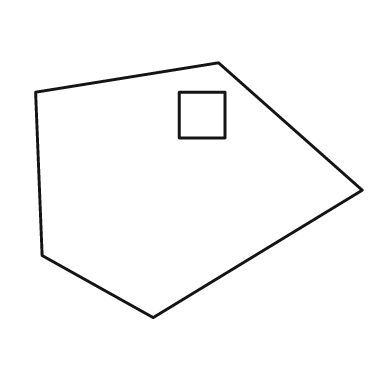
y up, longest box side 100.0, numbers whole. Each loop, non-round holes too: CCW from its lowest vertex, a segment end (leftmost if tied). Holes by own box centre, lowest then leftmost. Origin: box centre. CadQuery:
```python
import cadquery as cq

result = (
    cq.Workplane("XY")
    .moveTo(-14.0, -39.0)
    .lineTo(50.0, 0.0)
    .lineTo(6.0, 39.0)
    .lineTo(-50.0, 30.0)
    .lineTo(-48.0, -20.0)
    .close()
    .moveTo(-6.0, 16.0)
    .lineTo(8.0, 16.0)
    .lineTo(8.0, 30.0)
    .lineTo(-6.0, 30.0)
    .close()
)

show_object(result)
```